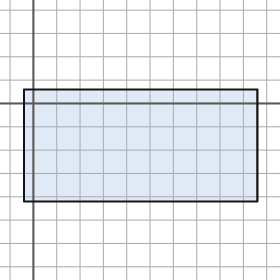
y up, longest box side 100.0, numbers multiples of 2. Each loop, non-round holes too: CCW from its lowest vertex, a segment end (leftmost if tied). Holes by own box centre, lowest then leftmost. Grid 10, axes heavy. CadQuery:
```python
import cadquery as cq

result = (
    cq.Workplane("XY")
    .moveTo(-4.0, -42.0)
    .lineTo(96.0, -42.0)
    .lineTo(96.0, 6.0)
    .lineTo(-4.0, 6.0)
    .close()
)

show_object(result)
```